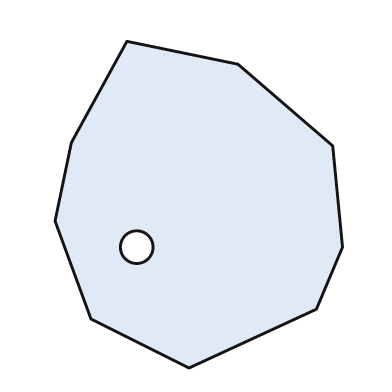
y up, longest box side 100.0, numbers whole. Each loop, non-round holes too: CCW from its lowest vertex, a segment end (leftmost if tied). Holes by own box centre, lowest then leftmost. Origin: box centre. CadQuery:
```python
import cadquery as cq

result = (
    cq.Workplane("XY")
    .moveTo(-3.0, -50.0)
    .lineTo(36.0, -32.0)
    .lineTo(44.0, -13.0)
    .lineTo(41.0, 18.0)
    .lineTo(12.0, 43.0)
    .lineTo(-22.0, 50.0)
    .lineTo(-39.0, 19.0)
    .lineTo(-44.0, -5.0)
    .lineTo(-33.0, -35.0)
    .close()
    .moveTo(-19.0, -13.0)
    .circle(5.0)
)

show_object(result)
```